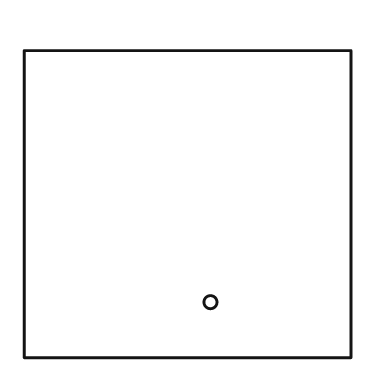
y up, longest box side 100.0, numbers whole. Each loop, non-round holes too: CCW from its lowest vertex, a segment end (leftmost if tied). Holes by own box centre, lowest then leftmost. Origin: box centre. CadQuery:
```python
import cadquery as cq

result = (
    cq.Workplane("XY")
    .moveTo(-50.0, -47.0)
    .lineTo(50.0, -47.0)
    .lineTo(50.0, 47.0)
    .lineTo(-50.0, 47.0)
    .close()
    .moveTo(7.0, -30.0)
    .circle(2.0)
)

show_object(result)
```